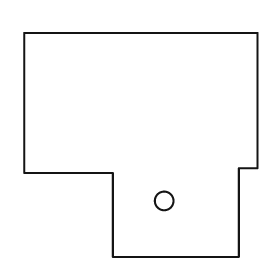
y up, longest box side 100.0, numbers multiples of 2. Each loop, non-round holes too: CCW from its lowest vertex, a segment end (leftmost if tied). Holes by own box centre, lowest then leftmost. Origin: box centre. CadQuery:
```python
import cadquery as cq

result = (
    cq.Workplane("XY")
    .moveTo(-12.0, -48.0)
    .lineTo(42.0, -48.0)
    .lineTo(42.0, -10.0)
    .lineTo(50.0, -10.0)
    .lineTo(50.0, 48.0)
    .lineTo(-50.0, 48.0)
    .lineTo(-50.0, -12.0)
    .lineTo(-12.0, -12.0)
    .close()
    .moveTo(10.0, -24.0)
    .circle(4.0)
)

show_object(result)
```